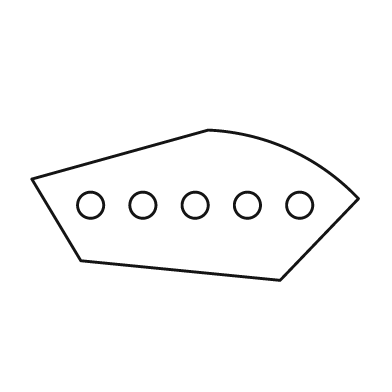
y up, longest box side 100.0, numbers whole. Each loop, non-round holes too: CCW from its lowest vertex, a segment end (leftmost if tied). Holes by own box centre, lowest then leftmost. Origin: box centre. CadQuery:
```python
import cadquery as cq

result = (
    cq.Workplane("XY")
    .moveTo(26.0, -23.0)
    .lineTo(50.0, 2.0)
    .threePointArc((29.0, 17.0), (4.0, 23.0))
    .lineTo(-50.0, 8.0)
    .lineTo(-35.0, -17.0)
    .close()
    .moveTo(-32.0, 0.0)
    .circle(4.0)
    .moveTo(-16.0, 0.0)
    .circle(4.0)
    .moveTo(0.0, 0.0)
    .circle(4.0)
    .moveTo(16.0, 0.0)
    .circle(4.0)
    .moveTo(32.0, 0.0)
    .circle(4.0)
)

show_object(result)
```